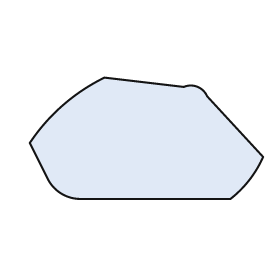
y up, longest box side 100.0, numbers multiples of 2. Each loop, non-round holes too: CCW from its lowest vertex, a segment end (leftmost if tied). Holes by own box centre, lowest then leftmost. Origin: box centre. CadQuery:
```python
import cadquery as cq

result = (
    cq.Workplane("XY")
    .moveTo(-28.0, -26.0)
    .lineTo(36.0, -26.0)
    .threePointArc((44.0, -18.0), (50.0, -8.0))
    .lineTo(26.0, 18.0)
    .threePointArc((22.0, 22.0), (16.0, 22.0))
    .lineTo(-18.0, 26.0)
    .threePointArc((-36.0, 14.0), (-50.0, -2.0))
    .lineTo(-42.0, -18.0)
    .threePointArc((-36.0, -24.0), (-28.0, -26.0))
    .close()
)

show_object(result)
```